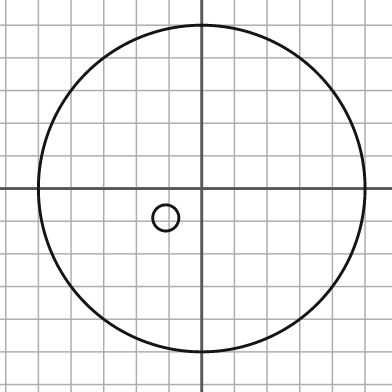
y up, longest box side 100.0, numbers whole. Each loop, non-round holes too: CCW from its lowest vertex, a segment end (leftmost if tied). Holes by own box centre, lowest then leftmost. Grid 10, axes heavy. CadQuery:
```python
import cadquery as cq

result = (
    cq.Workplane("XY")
    .moveTo(0.0, 0.0)
    .circle(50.0)
    .moveTo(-11.0, -9.0)
    .circle(4.0)
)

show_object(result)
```